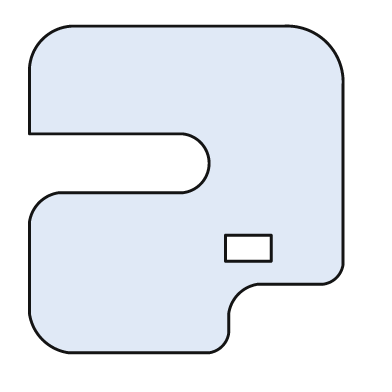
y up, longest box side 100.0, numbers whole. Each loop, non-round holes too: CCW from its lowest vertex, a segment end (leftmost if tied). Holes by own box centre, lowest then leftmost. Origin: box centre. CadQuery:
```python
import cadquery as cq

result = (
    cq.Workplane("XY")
    .moveTo(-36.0, -50.0)
    .lineTo(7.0, -50.0)
    .threePointArc((11.0, -48.0), (13.0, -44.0))
    .lineTo(13.0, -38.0)
    .threePointArc((16.0, -32.0), (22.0, -29.0))
    .lineTo(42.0, -29.0)
    .threePointArc((46.0, -27.0), (48.0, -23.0))
    .lineTo(48.0, 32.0)
    .threePointArc((43.0, 45.0), (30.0, 50.0))
    .lineTo(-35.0, 50.0)
    .threePointArc((-44.0, 46.0), (-48.0, 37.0))
    .lineTo(-48.0, 17.0)
    .lineTo(-1.0, 17.0)
    .threePointArc((7.0, 8.0), (-1.0, -1.0))
    .lineTo(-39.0, -1.0)
    .threePointArc((-45.0, -4.0), (-48.0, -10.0))
    .lineTo(-48.0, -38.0)
    .threePointArc((-44.0, -46.0), (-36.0, -50.0))
    .close()
    .moveTo(12.0, -22.0)
    .lineTo(26.0, -22.0)
    .lineTo(26.0, -14.0)
    .lineTo(12.0, -14.0)
    .close()
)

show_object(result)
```